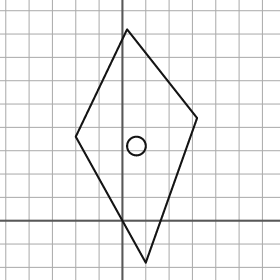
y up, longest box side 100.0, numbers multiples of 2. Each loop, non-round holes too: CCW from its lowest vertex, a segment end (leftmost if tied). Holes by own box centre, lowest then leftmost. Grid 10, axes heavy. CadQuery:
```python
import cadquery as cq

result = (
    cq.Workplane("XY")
    .moveTo(10.0, -18.0)
    .lineTo(32.0, 44.0)
    .lineTo(2.0, 82.0)
    .lineTo(-20.0, 36.0)
    .close()
    .moveTo(6.0, 32.0)
    .circle(4.0)
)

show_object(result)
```